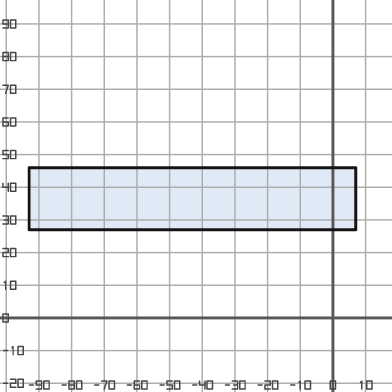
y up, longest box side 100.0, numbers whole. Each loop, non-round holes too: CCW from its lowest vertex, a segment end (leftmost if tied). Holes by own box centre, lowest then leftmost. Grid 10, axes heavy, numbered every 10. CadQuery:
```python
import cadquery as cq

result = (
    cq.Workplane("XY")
    .moveTo(-93.0, 27.0)
    .lineTo(7.0, 27.0)
    .lineTo(7.0, 46.0)
    .lineTo(-93.0, 46.0)
    .close()
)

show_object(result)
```